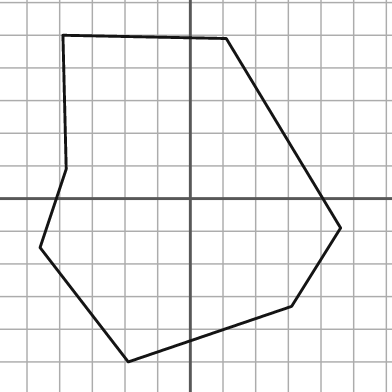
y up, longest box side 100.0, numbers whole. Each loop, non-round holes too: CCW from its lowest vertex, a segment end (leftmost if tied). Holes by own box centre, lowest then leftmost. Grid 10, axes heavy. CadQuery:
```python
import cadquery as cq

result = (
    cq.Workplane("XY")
    .moveTo(-19.0, -50.0)
    .lineTo(31.0, -33.0)
    .lineTo(46.0, -9.0)
    .lineTo(11.0, 49.0)
    .lineTo(-39.0, 50.0)
    .lineTo(-38.0, 9.0)
    .lineTo(-46.0, -15.0)
    .close()
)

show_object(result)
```